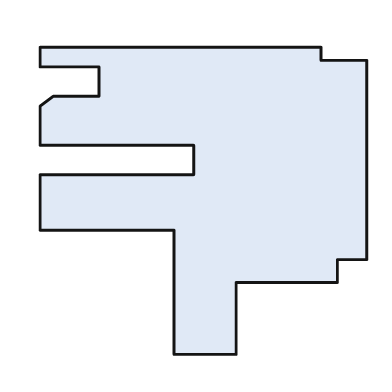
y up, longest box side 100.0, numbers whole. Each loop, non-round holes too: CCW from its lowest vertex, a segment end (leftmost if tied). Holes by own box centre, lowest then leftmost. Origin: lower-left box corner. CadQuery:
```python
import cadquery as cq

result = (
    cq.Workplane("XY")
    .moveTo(41.0, 0.0)
    .lineTo(60.0, 0.0)
    .lineTo(60.0, 22.0)
    .lineTo(91.0, 22.0)
    .lineTo(91.0, 29.0)
    .lineTo(100.0, 29.0)
    .lineTo(100.0, 90.0)
    .lineTo(86.0, 90.0)
    .lineTo(86.0, 94.0)
    .lineTo(0.0, 94.0)
    .lineTo(0.0, 88.0)
    .lineTo(18.0, 88.0)
    .lineTo(18.0, 79.0)
    .lineTo(4.0, 79.0)
    .lineTo(0.0, 76.0)
    .lineTo(0.0, 64.0)
    .lineTo(47.0, 64.0)
    .lineTo(47.0, 55.0)
    .lineTo(0.0, 55.0)
    .lineTo(0.0, 38.0)
    .lineTo(41.0, 38.0)
    .close()
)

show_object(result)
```